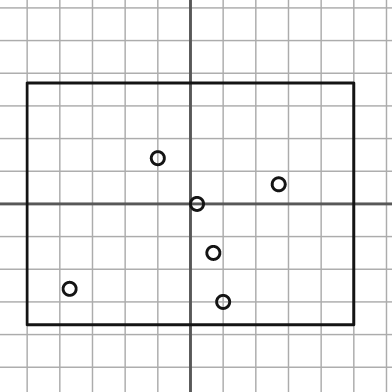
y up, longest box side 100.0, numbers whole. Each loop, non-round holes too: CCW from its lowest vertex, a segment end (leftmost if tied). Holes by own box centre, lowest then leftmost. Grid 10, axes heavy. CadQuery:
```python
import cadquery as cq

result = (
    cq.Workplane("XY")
    .moveTo(-50.0, -37.0)
    .lineTo(50.0, -37.0)
    .lineTo(50.0, 37.0)
    .lineTo(-50.0, 37.0)
    .close()
    .moveTo(10.0, -30.0)
    .circle(2.0)
    .moveTo(-37.0, -26.0)
    .circle(2.0)
    .moveTo(7.0, -15.0)
    .circle(2.0)
    .moveTo(2.0, 0.0)
    .circle(2.0)
    .moveTo(27.0, 6.0)
    .circle(2.0)
    .moveTo(-10.0, 14.0)
    .circle(2.0)
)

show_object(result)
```